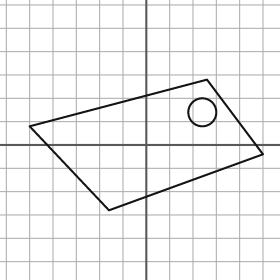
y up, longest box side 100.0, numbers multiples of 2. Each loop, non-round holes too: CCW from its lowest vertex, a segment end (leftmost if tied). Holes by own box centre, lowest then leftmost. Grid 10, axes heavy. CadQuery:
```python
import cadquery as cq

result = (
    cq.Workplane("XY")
    .moveTo(-16.0, -28.0)
    .lineTo(50.0, -4.0)
    .lineTo(26.0, 28.0)
    .lineTo(-50.0, 8.0)
    .close()
    .moveTo(24.0, 14.0)
    .circle(6.0)
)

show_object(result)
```